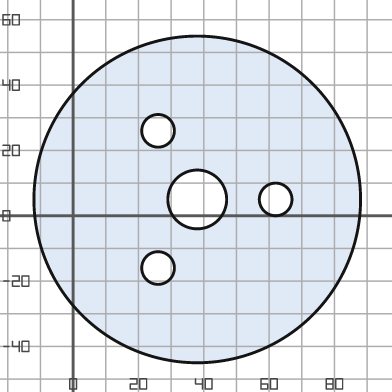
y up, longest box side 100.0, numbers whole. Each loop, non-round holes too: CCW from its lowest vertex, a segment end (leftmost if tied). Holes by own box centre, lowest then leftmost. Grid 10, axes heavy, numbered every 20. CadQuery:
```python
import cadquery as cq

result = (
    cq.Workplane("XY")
    .moveTo(38.0, 5.0)
    .circle(50.0)
    .moveTo(26.0, -16.0)
    .circle(5.0)
    .moveTo(38.0, 5.0)
    .circle(9.0)
    .moveTo(62.0, 5.0)
    .circle(5.0)
    .moveTo(26.0, 26.0)
    .circle(5.0)
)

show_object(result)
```